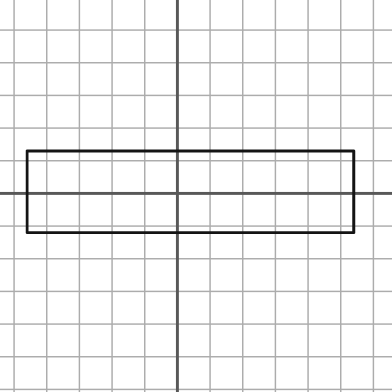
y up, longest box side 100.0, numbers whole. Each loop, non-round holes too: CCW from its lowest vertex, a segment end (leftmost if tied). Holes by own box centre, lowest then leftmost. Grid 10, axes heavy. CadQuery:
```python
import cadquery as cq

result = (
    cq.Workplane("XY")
    .moveTo(-46.0, -12.0)
    .lineTo(54.0, -12.0)
    .lineTo(54.0, 13.0)
    .lineTo(-46.0, 13.0)
    .close()
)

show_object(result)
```